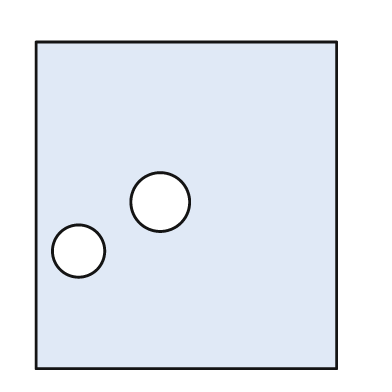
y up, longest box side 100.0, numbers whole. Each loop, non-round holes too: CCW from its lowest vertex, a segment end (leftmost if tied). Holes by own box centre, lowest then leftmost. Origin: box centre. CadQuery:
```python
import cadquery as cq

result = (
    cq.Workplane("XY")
    .moveTo(-46.0, -50.0)
    .lineTo(46.0, -50.0)
    .lineTo(46.0, 50.0)
    .lineTo(-46.0, 50.0)
    .close()
    .moveTo(-33.0, -14.0)
    .circle(8.0)
    .moveTo(-8.0, 1.0)
    .circle(9.0)
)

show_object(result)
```